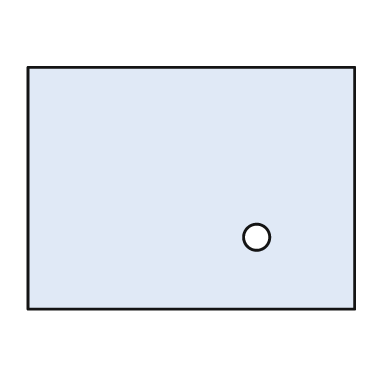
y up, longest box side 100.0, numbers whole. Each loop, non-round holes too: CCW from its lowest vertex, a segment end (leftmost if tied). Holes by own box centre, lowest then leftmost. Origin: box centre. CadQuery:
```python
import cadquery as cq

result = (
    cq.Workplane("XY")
    .moveTo(-50.0, -37.0)
    .lineTo(50.0, -37.0)
    .lineTo(50.0, 37.0)
    .lineTo(-50.0, 37.0)
    .close()
    .moveTo(20.0, -15.0)
    .circle(4.0)
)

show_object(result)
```